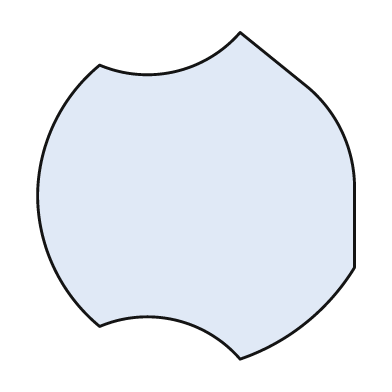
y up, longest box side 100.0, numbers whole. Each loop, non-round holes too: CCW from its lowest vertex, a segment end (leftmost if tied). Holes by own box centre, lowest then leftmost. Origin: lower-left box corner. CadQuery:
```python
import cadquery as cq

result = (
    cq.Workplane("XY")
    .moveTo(62.0, 0.0)
    .threePointArc((82.0, 11.0), (97.0, 28.0))
    .lineTo(97.0, 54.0)
    .threePointArc((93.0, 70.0), (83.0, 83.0))
    .lineTo(62.0, 100.0)
    .threePointArc((42.0, 88.0), (19.0, 90.0))
    .threePointArc((5.0, 72.0), (0.0, 50.0))
    .threePointArc((5.0, 28.0), (19.0, 10.0))
    .threePointArc((42.0, 12.0), (62.0, 0.0))
    .close()
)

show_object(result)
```